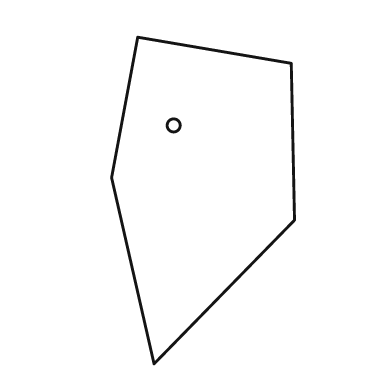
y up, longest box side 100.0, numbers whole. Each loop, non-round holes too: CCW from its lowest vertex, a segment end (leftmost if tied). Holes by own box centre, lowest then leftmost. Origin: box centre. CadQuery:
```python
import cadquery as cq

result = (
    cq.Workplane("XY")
    .moveTo(-15.0, -50.0)
    .lineTo(28.0, -6.0)
    .lineTo(27.0, 42.0)
    .lineTo(-20.0, 50.0)
    .lineTo(-28.0, 7.0)
    .close()
    .moveTo(-9.0, 23.0)
    .circle(2.0)
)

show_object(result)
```